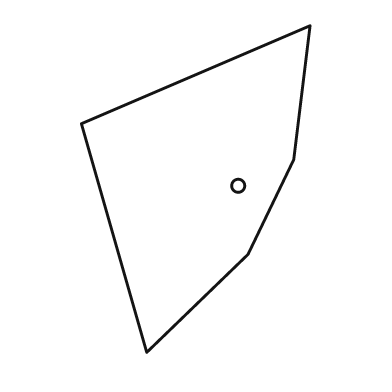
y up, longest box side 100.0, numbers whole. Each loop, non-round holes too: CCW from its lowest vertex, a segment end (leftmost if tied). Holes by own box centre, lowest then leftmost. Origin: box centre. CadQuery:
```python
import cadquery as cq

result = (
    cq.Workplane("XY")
    .moveTo(-15.0, -50.0)
    .lineTo(16.0, -20.0)
    .lineTo(30.0, 9.0)
    .lineTo(35.0, 50.0)
    .lineTo(-35.0, 20.0)
    .close()
    .moveTo(13.0, 1.0)
    .circle(2.0)
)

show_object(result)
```